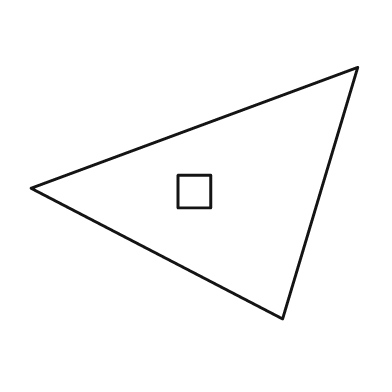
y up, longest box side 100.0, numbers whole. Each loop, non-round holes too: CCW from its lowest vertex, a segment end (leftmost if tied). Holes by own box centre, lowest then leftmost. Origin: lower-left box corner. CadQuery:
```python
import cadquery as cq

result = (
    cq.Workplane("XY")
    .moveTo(77.0, 0.0)
    .lineTo(100.0, 77.0)
    .lineTo(0.0, 40.0)
    .close()
    .moveTo(45.0, 34.0)
    .lineTo(55.0, 34.0)
    .lineTo(55.0, 44.0)
    .lineTo(45.0, 44.0)
    .close()
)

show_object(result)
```